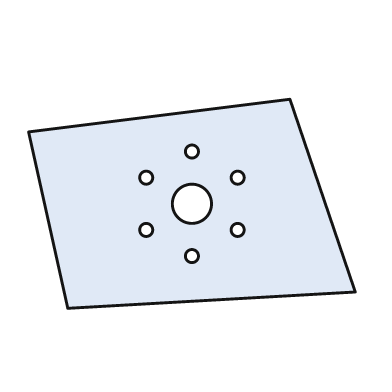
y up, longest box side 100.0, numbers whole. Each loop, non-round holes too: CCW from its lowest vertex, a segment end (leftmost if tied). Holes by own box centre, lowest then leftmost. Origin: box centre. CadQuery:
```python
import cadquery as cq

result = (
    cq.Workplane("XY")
    .moveTo(-38.0, -32.0)
    .lineTo(50.0, -27.0)
    .lineTo(30.0, 32.0)
    .lineTo(-50.0, 22.0)
    .close()
    .moveTo(0.0, -16.0)
    .circle(2.0)
    .moveTo(-14.0, -8.0)
    .circle(2.0)
    .moveTo(14.0, -8.0)
    .circle(2.0)
    .moveTo(0.0, 0.0)
    .circle(6.0)
    .moveTo(-14.0, 8.0)
    .circle(2.0)
    .moveTo(14.0, 8.0)
    .circle(2.0)
    .moveTo(0.0, 16.0)
    .circle(2.0)
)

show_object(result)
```